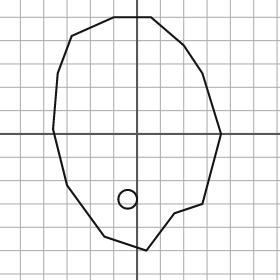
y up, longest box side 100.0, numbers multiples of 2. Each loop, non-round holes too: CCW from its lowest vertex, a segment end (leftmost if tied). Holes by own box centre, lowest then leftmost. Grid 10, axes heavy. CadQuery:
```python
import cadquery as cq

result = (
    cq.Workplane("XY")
    .moveTo(4.0, -50.0)
    .lineTo(16.0, -34.0)
    .lineTo(28.0, -30.0)
    .lineTo(36.0, 0.0)
    .lineTo(28.0, 26.0)
    .lineTo(20.0, 38.0)
    .lineTo(6.0, 50.0)
    .lineTo(-10.0, 50.0)
    .lineTo(-28.0, 42.0)
    .lineTo(-34.0, 26.0)
    .lineTo(-36.0, 2.0)
    .lineTo(-30.0, -22.0)
    .lineTo(-14.0, -44.0)
    .close()
    .moveTo(-4.0, -28.0)
    .circle(4.0)
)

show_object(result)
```